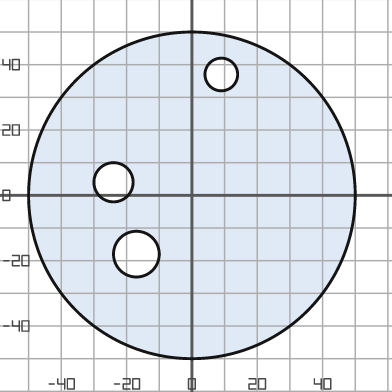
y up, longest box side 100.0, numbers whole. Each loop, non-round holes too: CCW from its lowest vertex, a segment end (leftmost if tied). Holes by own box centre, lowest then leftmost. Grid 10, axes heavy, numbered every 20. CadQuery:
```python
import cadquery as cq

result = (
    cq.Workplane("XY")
    .moveTo(0.0, 0.0)
    .circle(50.0)
    .moveTo(-17.0, -18.0)
    .circle(7.0)
    .moveTo(-24.0, 4.0)
    .circle(6.0)
    .moveTo(9.0, 37.0)
    .circle(5.0)
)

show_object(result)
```